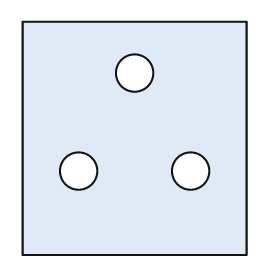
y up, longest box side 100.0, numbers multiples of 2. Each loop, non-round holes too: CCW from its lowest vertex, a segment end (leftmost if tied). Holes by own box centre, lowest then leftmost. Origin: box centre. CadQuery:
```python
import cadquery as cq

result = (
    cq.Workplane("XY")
    .moveTo(-48.0, -50.0)
    .lineTo(48.0, -50.0)
    .lineTo(48.0, 50.0)
    .lineTo(-48.0, 50.0)
    .close()
    .moveTo(-24.0, -14.0)
    .circle(8.0)
    .moveTo(24.0, -14.0)
    .circle(8.0)
    .moveTo(0.0, 28.0)
    .circle(8.0)
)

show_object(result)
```